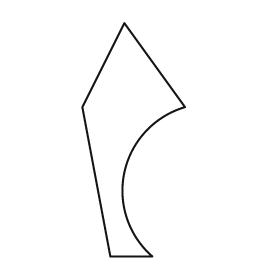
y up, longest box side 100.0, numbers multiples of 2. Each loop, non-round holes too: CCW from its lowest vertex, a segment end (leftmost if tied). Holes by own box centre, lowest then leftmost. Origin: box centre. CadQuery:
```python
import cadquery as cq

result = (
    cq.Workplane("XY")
    .moveTo(-10.0, -50.0)
    .lineTo(8.0, -50.0)
    .threePointArc((-4.0, -14.0), (22.0, 14.0))
    .lineTo(-4.0, 50.0)
    .lineTo(-22.0, 14.0)
    .close()
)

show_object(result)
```